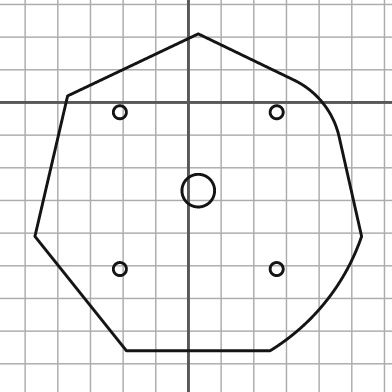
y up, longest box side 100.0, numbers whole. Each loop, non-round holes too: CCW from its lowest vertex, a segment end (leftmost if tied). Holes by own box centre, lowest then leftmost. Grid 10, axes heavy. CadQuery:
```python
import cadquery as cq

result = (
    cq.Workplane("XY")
    .moveTo(-19.0, -76.0)
    .lineTo(25.0, -76.0)
    .threePointArc((42.0, -61.0), (53.0, -41.0))
    .lineTo(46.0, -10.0)
    .threePointArc((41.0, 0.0), (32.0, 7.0))
    .lineTo(3.0, 21.0)
    .lineTo(-37.0, 2.0)
    .lineTo(-47.0, -41.0)
    .close()
    .moveTo(-21.0, -51.0)
    .circle(2.0)
    .moveTo(27.0, -51.0)
    .circle(2.0)
    .moveTo(3.0, -27.0)
    .circle(5.0)
    .moveTo(-21.0, -3.0)
    .circle(2.0)
    .moveTo(27.0, -3.0)
    .circle(2.0)
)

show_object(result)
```